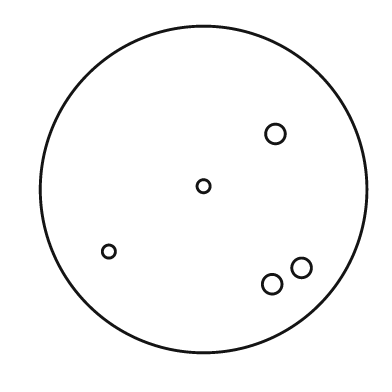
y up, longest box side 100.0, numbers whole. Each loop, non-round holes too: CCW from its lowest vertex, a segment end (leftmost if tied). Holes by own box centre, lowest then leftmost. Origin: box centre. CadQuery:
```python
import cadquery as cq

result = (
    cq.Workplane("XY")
    .moveTo(0.0, 0.0)
    .circle(50.0)
    .moveTo(21.0, -29.0)
    .circle(3.0)
    .moveTo(30.0, -24.0)
    .circle(3.0)
    .moveTo(-29.0, -19.0)
    .circle(2.0)
    .moveTo(0.0, 1.0)
    .circle(2.0)
    .moveTo(22.0, 17.0)
    .circle(3.0)
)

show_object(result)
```